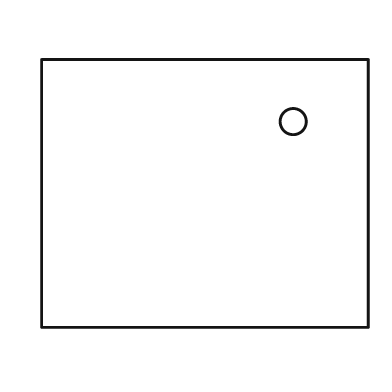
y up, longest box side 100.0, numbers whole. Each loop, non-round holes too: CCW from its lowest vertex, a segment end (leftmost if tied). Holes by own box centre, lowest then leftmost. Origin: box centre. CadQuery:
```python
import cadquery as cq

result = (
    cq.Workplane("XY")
    .moveTo(-50.0, -41.0)
    .lineTo(50.0, -41.0)
    .lineTo(50.0, 41.0)
    .lineTo(-50.0, 41.0)
    .close()
    .moveTo(27.0, 22.0)
    .circle(4.0)
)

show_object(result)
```